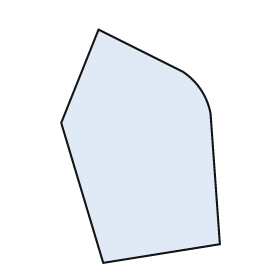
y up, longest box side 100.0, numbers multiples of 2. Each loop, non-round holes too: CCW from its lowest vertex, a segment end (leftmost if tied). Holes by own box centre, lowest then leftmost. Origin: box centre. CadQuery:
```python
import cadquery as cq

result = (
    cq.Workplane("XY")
    .moveTo(-16.0, -50.0)
    .lineTo(34.0, -42.0)
    .lineTo(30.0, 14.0)
    .threePointArc((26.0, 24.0), (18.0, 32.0))
    .lineTo(-18.0, 50.0)
    .lineTo(-34.0, 10.0)
    .close()
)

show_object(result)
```